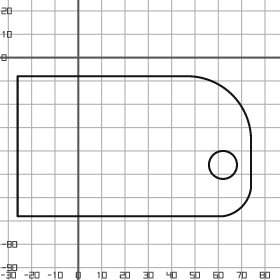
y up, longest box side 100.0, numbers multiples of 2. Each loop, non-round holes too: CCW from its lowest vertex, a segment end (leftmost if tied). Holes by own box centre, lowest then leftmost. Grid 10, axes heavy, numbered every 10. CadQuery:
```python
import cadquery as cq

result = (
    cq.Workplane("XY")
    .moveTo(-26.0, -68.0)
    .lineTo(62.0, -68.0)
    .threePointArc((70.0, -64.0), (74.0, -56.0))
    .lineTo(74.0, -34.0)
    .threePointArc((66.0, -16.0), (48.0, -8.0))
    .lineTo(-26.0, -8.0)
    .close()
    .moveTo(62.0, -46.0)
    .circle(6.0)
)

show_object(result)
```